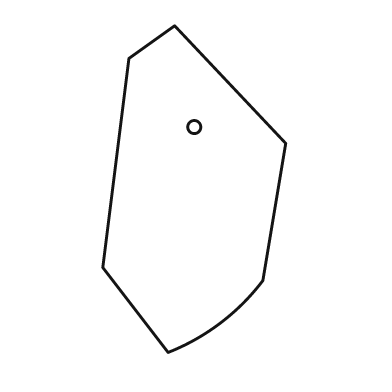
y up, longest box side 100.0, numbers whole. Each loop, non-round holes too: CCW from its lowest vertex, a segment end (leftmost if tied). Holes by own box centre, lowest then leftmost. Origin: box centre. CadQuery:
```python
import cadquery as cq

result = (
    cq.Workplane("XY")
    .moveTo(-8.0, -50.0)
    .threePointArc((8.0, -41.0), (21.0, -28.0))
    .lineTo(28.0, 14.0)
    .lineTo(-6.0, 50.0)
    .lineTo(-20.0, 40.0)
    .lineTo(-28.0, -24.0)
    .close()
    .moveTo(0.0, 19.0)
    .circle(2.0)
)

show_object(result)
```